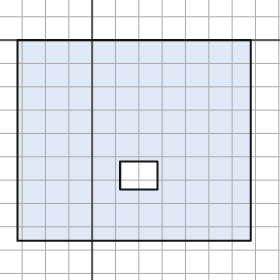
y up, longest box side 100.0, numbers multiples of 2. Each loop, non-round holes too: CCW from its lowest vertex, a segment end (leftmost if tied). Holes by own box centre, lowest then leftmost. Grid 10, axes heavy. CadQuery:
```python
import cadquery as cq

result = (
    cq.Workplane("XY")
    .moveTo(-32.0, -86.0)
    .lineTo(68.0, -86.0)
    .lineTo(68.0, 0.0)
    .lineTo(-32.0, 0.0)
    .close()
    .moveTo(12.0, -64.0)
    .lineTo(28.0, -64.0)
    .lineTo(28.0, -52.0)
    .lineTo(12.0, -52.0)
    .close()
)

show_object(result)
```